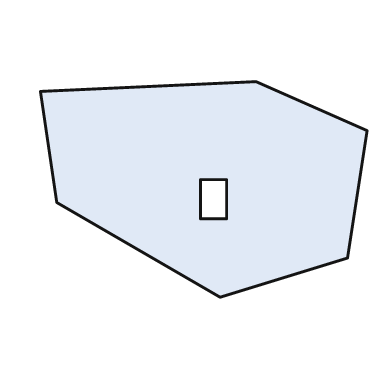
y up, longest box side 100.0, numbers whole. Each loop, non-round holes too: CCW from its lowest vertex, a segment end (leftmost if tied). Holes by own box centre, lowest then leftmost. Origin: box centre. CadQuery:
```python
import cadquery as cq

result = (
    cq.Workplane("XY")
    .moveTo(5.0, -33.0)
    .lineTo(44.0, -21.0)
    .lineTo(50.0, 18.0)
    .lineTo(16.0, 33.0)
    .lineTo(-50.0, 30.0)
    .lineTo(-45.0, -4.0)
    .close()
    .moveTo(-1.0, -9.0)
    .lineTo(7.0, -9.0)
    .lineTo(7.0, 3.0)
    .lineTo(-1.0, 3.0)
    .close()
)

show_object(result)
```